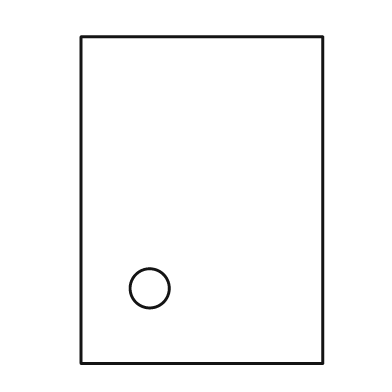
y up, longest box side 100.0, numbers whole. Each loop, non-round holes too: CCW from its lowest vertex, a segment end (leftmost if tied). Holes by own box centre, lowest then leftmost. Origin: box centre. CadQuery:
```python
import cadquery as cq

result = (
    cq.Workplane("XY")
    .moveTo(-37.0, -50.0)
    .lineTo(37.0, -50.0)
    .lineTo(37.0, 50.0)
    .lineTo(-37.0, 50.0)
    .close()
    .moveTo(-16.0, -27.0)
    .circle(6.0)
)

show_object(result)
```